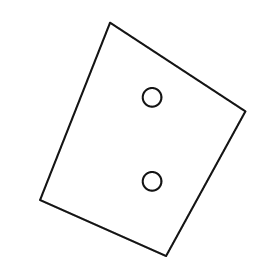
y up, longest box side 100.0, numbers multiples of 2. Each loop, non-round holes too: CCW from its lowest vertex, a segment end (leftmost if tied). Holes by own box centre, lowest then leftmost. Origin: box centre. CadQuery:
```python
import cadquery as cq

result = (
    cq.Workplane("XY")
    .moveTo(10.0, -50.0)
    .lineTo(44.0, 12.0)
    .lineTo(-14.0, 50.0)
    .lineTo(-44.0, -26.0)
    .close()
    .moveTo(4.0, -18.0)
    .circle(4.0)
    .moveTo(4.0, 18.0)
    .circle(4.0)
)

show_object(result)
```